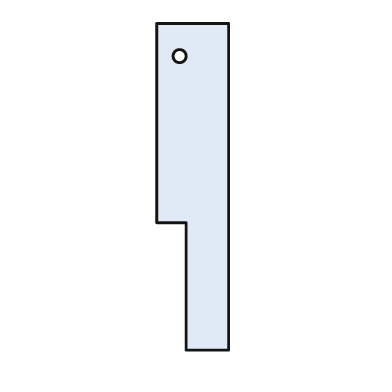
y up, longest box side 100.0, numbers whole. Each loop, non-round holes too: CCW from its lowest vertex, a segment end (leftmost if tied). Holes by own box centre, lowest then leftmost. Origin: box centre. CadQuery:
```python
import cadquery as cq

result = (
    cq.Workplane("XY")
    .moveTo(-2.0, -50.0)
    .lineTo(11.0, -50.0)
    .lineTo(11.0, 50.0)
    .lineTo(-11.0, 50.0)
    .lineTo(-11.0, -11.0)
    .lineTo(-2.0, -11.0)
    .close()
    .moveTo(-4.0, 40.0)
    .circle(2.0)
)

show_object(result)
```